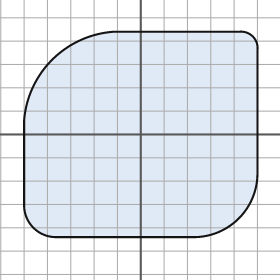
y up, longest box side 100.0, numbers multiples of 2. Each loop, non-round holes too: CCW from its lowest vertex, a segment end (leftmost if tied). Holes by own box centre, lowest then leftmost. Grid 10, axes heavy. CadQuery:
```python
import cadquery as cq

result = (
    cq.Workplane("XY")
    .moveTo(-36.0, -44.0)
    .lineTo(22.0, -44.0)
    .threePointArc((42.0, -36.0), (50.0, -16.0))
    .lineTo(50.0, 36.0)
    .threePointArc((48.0, 42.0), (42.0, 44.0))
    .lineTo(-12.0, 44.0)
    .threePointArc((-38.0, 32.0), (-50.0, 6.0))
    .lineTo(-50.0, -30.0)
    .threePointArc((-46.0, -40.0), (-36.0, -44.0))
    .close()
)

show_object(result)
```